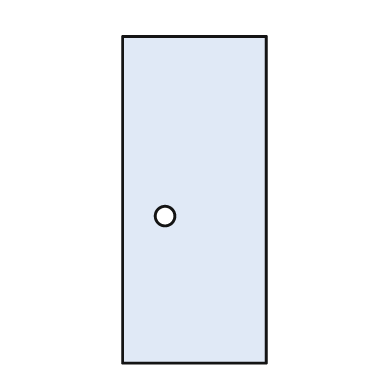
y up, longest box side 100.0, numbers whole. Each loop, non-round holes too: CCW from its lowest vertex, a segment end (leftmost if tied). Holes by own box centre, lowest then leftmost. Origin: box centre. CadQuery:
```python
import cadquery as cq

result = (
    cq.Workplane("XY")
    .moveTo(-22.0, -50.0)
    .lineTo(22.0, -50.0)
    .lineTo(22.0, 50.0)
    .lineTo(-22.0, 50.0)
    .close()
    .moveTo(-9.0, -5.0)
    .circle(3.0)
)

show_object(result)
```